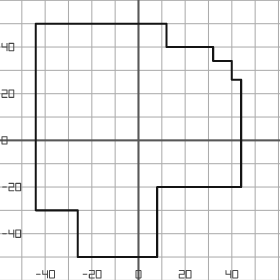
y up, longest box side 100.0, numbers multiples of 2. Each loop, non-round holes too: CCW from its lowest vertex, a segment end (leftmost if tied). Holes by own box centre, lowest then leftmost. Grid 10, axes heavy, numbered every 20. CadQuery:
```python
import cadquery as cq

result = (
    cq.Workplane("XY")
    .moveTo(-26.0, -50.0)
    .lineTo(8.0, -50.0)
    .lineTo(8.0, -20.0)
    .lineTo(44.0, -20.0)
    .lineTo(44.0, 26.0)
    .lineTo(40.0, 26.0)
    .lineTo(40.0, 34.0)
    .lineTo(32.0, 34.0)
    .lineTo(32.0, 40.0)
    .lineTo(12.0, 40.0)
    .lineTo(12.0, 50.0)
    .lineTo(-44.0, 50.0)
    .lineTo(-44.0, -30.0)
    .lineTo(-26.0, -30.0)
    .close()
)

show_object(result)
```